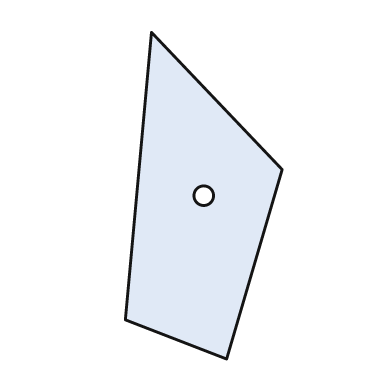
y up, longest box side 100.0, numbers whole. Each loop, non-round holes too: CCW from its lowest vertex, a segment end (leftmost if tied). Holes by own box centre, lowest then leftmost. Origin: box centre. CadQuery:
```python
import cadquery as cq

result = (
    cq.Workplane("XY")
    .moveTo(7.0, -50.0)
    .lineTo(24.0, 8.0)
    .lineTo(-16.0, 50.0)
    .lineTo(-24.0, -38.0)
    .close()
    .moveTo(0.0, 0.0)
    .circle(3.0)
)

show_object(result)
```